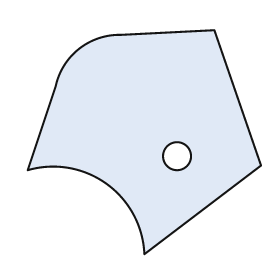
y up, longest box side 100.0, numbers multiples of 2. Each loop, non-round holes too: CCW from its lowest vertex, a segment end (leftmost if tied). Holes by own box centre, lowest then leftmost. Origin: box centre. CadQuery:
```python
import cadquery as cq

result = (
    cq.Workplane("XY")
    .moveTo(0.0, -48.0)
    .lineTo(50.0, -10.0)
    .lineTo(30.0, 48.0)
    .lineTo(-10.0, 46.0)
    .threePointArc((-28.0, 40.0), (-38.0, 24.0))
    .lineTo(-50.0, -12.0)
    .threePointArc((-16.0, -18.0), (0.0, -48.0))
    .close()
    .moveTo(14.0, -6.0)
    .circle(6.0)
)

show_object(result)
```